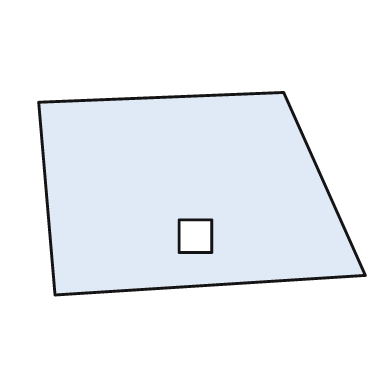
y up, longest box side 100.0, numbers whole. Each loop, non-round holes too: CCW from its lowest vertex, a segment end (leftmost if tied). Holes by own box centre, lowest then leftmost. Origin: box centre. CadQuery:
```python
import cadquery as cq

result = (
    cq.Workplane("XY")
    .moveTo(-45.0, -31.0)
    .lineTo(50.0, -25.0)
    .lineTo(25.0, 31.0)
    .lineTo(-50.0, 28.0)
    .close()
    .moveTo(-7.0, -18.0)
    .lineTo(3.0, -18.0)
    .lineTo(3.0, -8.0)
    .lineTo(-7.0, -8.0)
    .close()
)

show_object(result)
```